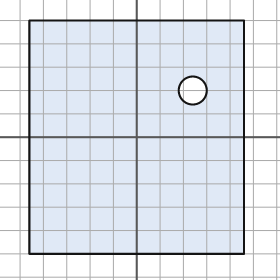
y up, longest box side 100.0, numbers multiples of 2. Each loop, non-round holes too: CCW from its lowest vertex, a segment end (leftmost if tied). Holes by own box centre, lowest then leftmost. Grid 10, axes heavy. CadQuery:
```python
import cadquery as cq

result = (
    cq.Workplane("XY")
    .moveTo(-46.0, -50.0)
    .lineTo(46.0, -50.0)
    .lineTo(46.0, 50.0)
    .lineTo(-46.0, 50.0)
    .close()
    .moveTo(24.0, 20.0)
    .circle(6.0)
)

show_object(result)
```